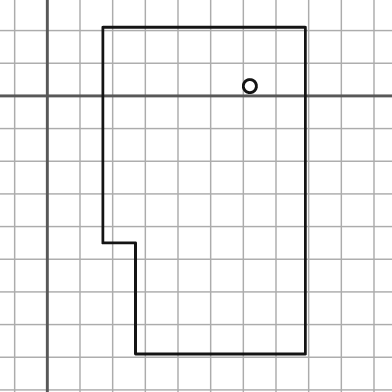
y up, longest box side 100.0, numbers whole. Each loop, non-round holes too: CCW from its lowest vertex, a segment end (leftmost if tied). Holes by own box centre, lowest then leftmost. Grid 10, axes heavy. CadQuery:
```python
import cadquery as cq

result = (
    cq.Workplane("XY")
    .moveTo(27.0, -79.0)
    .lineTo(79.0, -79.0)
    .lineTo(79.0, 21.0)
    .lineTo(17.0, 21.0)
    .lineTo(17.0, -45.0)
    .lineTo(27.0, -45.0)
    .close()
    .moveTo(62.0, 3.0)
    .circle(2.0)
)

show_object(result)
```